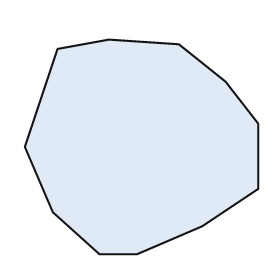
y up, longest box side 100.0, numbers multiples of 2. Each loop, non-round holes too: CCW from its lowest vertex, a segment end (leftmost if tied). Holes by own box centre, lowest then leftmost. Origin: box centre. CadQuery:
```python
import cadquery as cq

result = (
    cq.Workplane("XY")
    .moveTo(-18.0, -46.0)
    .lineTo(-2.0, -46.0)
    .lineTo(26.0, -34.0)
    .lineTo(50.0, -18.0)
    .lineTo(50.0, 10.0)
    .lineTo(36.0, 28.0)
    .lineTo(16.0, 44.0)
    .lineTo(-14.0, 46.0)
    .lineTo(-36.0, 42.0)
    .lineTo(-50.0, 0.0)
    .lineTo(-38.0, -28.0)
    .close()
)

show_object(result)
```